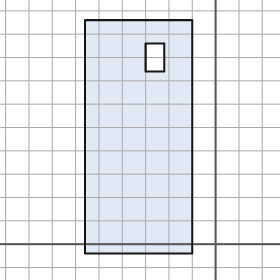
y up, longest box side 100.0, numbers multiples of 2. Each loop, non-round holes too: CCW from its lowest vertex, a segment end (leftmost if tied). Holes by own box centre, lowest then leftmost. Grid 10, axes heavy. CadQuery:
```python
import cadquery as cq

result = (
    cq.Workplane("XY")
    .moveTo(-56.0, -4.0)
    .lineTo(-10.0, -4.0)
    .lineTo(-10.0, 96.0)
    .lineTo(-56.0, 96.0)
    .close()
    .moveTo(-30.0, 74.0)
    .lineTo(-22.0, 74.0)
    .lineTo(-22.0, 86.0)
    .lineTo(-30.0, 86.0)
    .close()
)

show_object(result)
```